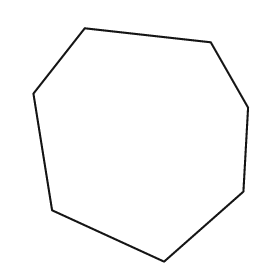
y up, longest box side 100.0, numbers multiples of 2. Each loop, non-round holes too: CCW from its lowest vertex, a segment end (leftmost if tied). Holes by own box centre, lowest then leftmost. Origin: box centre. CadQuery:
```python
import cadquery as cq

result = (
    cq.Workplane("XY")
    .moveTo(10.0, -50.0)
    .lineTo(44.0, -20.0)
    .lineTo(46.0, 16.0)
    .lineTo(30.0, 44.0)
    .lineTo(-24.0, 50.0)
    .lineTo(-46.0, 22.0)
    .lineTo(-38.0, -28.0)
    .close()
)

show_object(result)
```